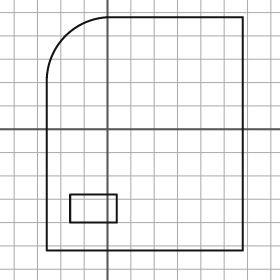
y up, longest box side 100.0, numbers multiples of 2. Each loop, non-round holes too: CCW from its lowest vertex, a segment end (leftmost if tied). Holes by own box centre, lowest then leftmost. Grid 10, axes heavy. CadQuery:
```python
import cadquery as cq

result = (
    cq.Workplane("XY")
    .moveTo(-26.0, -52.0)
    .lineTo(58.0, -52.0)
    .lineTo(58.0, 48.0)
    .lineTo(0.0, 48.0)
    .threePointArc((-18.0, 40.0), (-26.0, 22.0))
    .close()
    .moveTo(-16.0, -40.0)
    .lineTo(4.0, -40.0)
    .lineTo(4.0, -28.0)
    .lineTo(-16.0, -28.0)
    .close()
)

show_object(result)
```